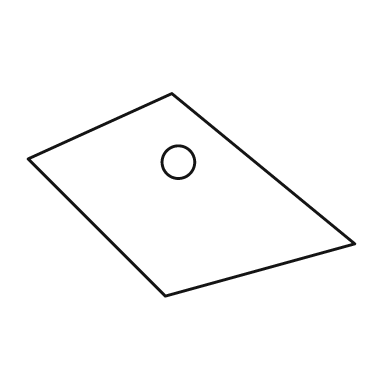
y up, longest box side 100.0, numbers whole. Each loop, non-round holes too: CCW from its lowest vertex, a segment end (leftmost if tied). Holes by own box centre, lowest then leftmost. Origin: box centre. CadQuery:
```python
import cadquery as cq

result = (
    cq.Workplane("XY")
    .moveTo(-8.0, -31.0)
    .lineTo(50.0, -15.0)
    .lineTo(-6.0, 31.0)
    .lineTo(-50.0, 11.0)
    .close()
    .moveTo(-4.0, 10.0)
    .circle(5.0)
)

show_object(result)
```